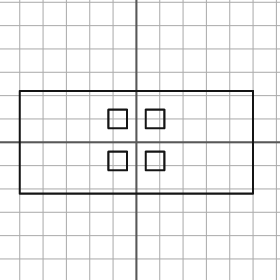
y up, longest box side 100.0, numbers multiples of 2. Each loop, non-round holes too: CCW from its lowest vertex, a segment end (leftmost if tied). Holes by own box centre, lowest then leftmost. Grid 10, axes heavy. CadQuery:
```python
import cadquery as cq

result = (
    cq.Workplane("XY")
    .moveTo(-50.0, -22.0)
    .lineTo(50.0, -22.0)
    .lineTo(50.0, 22.0)
    .lineTo(-50.0, 22.0)
    .close()
    .moveTo(-12.0, -12.0)
    .lineTo(-4.0, -12.0)
    .lineTo(-4.0, -4.0)
    .lineTo(-12.0, -4.0)
    .close()
    .moveTo(4.0, -12.0)
    .lineTo(12.0, -12.0)
    .lineTo(12.0, -4.0)
    .lineTo(4.0, -4.0)
    .close()
    .moveTo(-12.0, 6.0)
    .lineTo(-4.0, 6.0)
    .lineTo(-4.0, 14.0)
    .lineTo(-12.0, 14.0)
    .close()
    .moveTo(4.0, 6.0)
    .lineTo(12.0, 6.0)
    .lineTo(12.0, 14.0)
    .lineTo(4.0, 14.0)
    .close()
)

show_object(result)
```